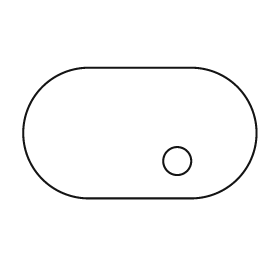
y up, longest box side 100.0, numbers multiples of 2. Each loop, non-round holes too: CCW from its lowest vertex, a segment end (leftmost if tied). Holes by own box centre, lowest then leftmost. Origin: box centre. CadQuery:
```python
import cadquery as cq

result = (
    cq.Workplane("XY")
    .moveTo(-22.0, -28.0)
    .lineTo(22.0, -28.0)
    .threePointArc((50.0, 0.0), (22.0, 28.0))
    .lineTo(-22.0, 28.0)
    .threePointArc((-50.0, 0.0), (-22.0, -28.0))
    .close()
    .moveTo(16.0, -12.0)
    .circle(6.0)
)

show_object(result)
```